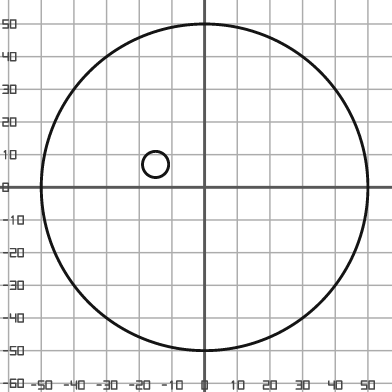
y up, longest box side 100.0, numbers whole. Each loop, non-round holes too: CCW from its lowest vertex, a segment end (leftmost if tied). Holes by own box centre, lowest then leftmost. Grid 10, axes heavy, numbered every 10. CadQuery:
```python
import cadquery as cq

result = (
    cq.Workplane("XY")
    .moveTo(0.0, 0.0)
    .circle(50.0)
    .moveTo(-15.0, 7.0)
    .circle(4.0)
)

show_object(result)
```